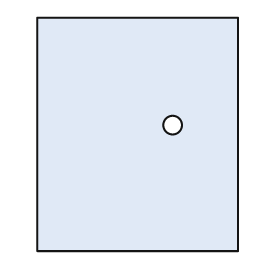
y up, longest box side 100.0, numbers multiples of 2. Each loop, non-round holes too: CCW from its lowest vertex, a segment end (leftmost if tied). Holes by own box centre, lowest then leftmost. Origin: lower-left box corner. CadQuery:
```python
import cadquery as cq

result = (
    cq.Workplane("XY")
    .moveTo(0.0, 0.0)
    .lineTo(86.0, 0.0)
    .lineTo(86.0, 100.0)
    .lineTo(0.0, 100.0)
    .close()
    .moveTo(58.0, 54.0)
    .circle(4.0)
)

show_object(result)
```